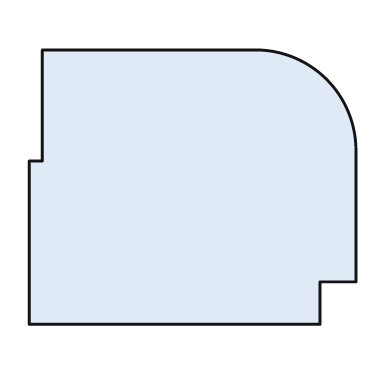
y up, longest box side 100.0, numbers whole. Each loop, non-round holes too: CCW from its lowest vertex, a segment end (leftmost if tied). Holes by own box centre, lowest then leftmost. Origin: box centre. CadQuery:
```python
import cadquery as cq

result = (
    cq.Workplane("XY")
    .moveTo(-50.0, -42.0)
    .lineTo(39.0, -42.0)
    .lineTo(39.0, -29.0)
    .lineTo(50.0, -29.0)
    .lineTo(50.0, 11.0)
    .threePointArc((41.0, 33.0), (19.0, 42.0))
    .lineTo(-46.0, 42.0)
    .lineTo(-46.0, 8.0)
    .lineTo(-50.0, 8.0)
    .close()
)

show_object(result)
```